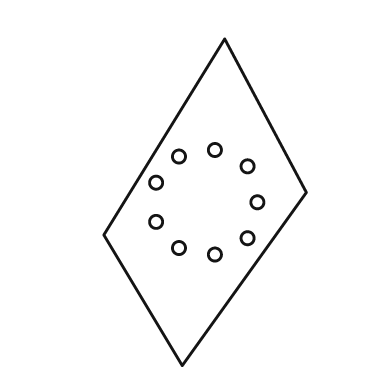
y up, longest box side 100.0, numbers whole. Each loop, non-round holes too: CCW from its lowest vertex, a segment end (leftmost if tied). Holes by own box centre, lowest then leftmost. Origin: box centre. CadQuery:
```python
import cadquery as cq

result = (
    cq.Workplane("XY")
    .moveTo(-7.0, -50.0)
    .lineTo(31.0, 3.0)
    .lineTo(6.0, 50.0)
    .lineTo(-31.0, -10.0)
    .close()
    .moveTo(3.0, -16.0)
    .circle(2.0)
    .moveTo(-8.0, -14.0)
    .circle(2.0)
    .moveTo(13.0, -11.0)
    .circle(2.0)
    .moveTo(-15.0, -6.0)
    .circle(2.0)
    .moveTo(16.0, 0.0)
    .circle(2.0)
    .moveTo(-15.0, 6.0)
    .circle(2.0)
    .moveTo(13.0, 11.0)
    .circle(2.0)
    .moveTo(-8.0, 14.0)
    .circle(2.0)
    .moveTo(3.0, 16.0)
    .circle(2.0)
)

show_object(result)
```